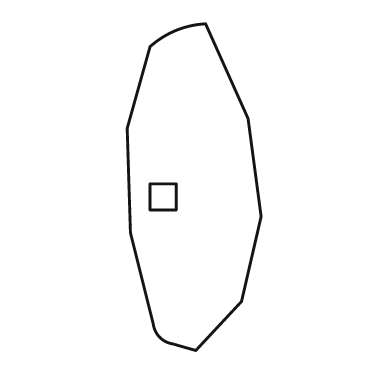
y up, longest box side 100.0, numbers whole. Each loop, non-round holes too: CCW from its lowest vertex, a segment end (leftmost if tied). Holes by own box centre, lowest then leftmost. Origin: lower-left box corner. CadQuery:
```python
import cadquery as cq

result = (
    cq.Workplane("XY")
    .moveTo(21.0, 0.0)
    .lineTo(35.0, 15.0)
    .lineTo(41.0, 41.0)
    .lineTo(37.0, 71.0)
    .lineTo(24.0, 100.0)
    .threePointArc((15.0, 98.0), (7.0, 93.0))
    .lineTo(0.0, 68.0)
    .lineTo(1.0, 36.0)
    .lineTo(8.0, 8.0)
    .threePointArc((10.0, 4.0), (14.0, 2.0))
    .close()
    .moveTo(7.0, 43.0)
    .lineTo(15.0, 43.0)
    .lineTo(15.0, 51.0)
    .lineTo(7.0, 51.0)
    .close()
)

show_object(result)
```